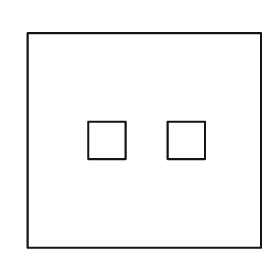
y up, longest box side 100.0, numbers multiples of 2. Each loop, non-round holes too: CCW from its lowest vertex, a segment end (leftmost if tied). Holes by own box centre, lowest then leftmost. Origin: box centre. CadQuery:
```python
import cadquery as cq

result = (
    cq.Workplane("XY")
    .moveTo(-50.0, -46.0)
    .lineTo(50.0, -46.0)
    .lineTo(50.0, 46.0)
    .lineTo(-50.0, 46.0)
    .close()
    .moveTo(-24.0, -8.0)
    .lineTo(-8.0, -8.0)
    .lineTo(-8.0, 8.0)
    .lineTo(-24.0, 8.0)
    .close()
    .moveTo(10.0, -8.0)
    .lineTo(26.0, -8.0)
    .lineTo(26.0, 8.0)
    .lineTo(10.0, 8.0)
    .close()
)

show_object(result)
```